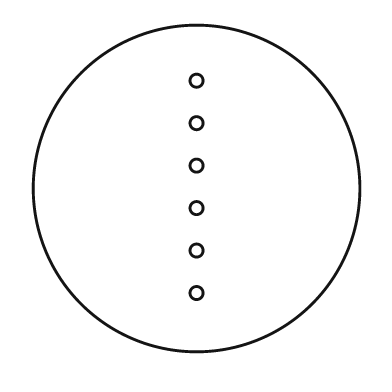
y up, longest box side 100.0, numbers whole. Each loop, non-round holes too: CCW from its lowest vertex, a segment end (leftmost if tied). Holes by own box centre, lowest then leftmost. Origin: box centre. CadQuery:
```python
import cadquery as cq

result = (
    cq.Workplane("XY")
    .moveTo(0.0, 0.0)
    .circle(50.0)
    .moveTo(0.0, -32.0)
    .circle(2.0)
    .moveTo(0.0, -19.0)
    .circle(2.0)
    .moveTo(0.0, -6.0)
    .circle(2.0)
    .moveTo(0.0, 7.0)
    .circle(2.0)
    .moveTo(0.0, 20.0)
    .circle(2.0)
    .moveTo(0.0, 33.0)
    .circle(2.0)
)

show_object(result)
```